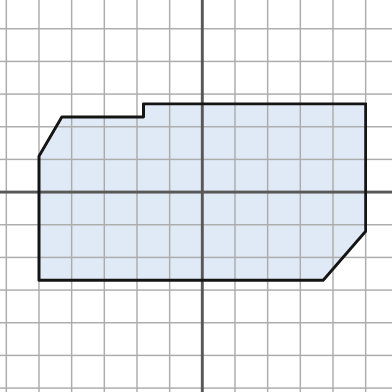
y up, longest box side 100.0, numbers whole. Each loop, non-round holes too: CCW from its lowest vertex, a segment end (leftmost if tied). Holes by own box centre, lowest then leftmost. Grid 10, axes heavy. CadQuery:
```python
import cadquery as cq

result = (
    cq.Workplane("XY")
    .moveTo(-50.0, -27.0)
    .lineTo(37.0, -27.0)
    .lineTo(50.0, -12.0)
    .lineTo(50.0, 27.0)
    .lineTo(-18.0, 27.0)
    .lineTo(-18.0, 23.0)
    .lineTo(-43.0, 23.0)
    .lineTo(-50.0, 11.0)
    .close()
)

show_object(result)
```